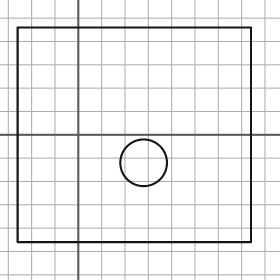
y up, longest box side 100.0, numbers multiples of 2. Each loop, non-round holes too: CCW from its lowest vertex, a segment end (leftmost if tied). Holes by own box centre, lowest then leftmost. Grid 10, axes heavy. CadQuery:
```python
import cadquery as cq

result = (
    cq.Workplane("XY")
    .moveTo(-26.0, -46.0)
    .lineTo(74.0, -46.0)
    .lineTo(74.0, 46.0)
    .lineTo(-26.0, 46.0)
    .close()
    .moveTo(28.0, -12.0)
    .circle(10.0)
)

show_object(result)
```